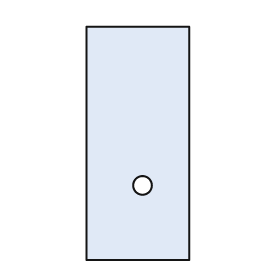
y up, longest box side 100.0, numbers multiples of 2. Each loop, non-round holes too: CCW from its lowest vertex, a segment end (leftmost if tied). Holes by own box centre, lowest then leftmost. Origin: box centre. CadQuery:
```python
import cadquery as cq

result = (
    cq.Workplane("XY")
    .moveTo(-22.0, -50.0)
    .lineTo(22.0, -50.0)
    .lineTo(22.0, 50.0)
    .lineTo(-22.0, 50.0)
    .close()
    .moveTo(2.0, -18.0)
    .circle(4.0)
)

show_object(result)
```